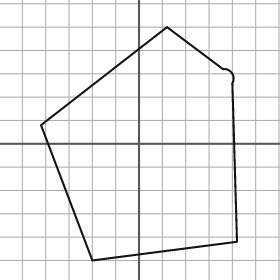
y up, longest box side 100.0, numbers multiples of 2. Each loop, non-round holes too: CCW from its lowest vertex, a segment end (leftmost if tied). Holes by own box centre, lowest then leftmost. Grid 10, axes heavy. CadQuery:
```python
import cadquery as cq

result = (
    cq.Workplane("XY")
    .moveTo(-20.0, -50.0)
    .lineTo(42.0, -42.0)
    .lineTo(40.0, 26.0)
    .threePointArc((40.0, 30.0), (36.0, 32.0))
    .lineTo(12.0, 50.0)
    .lineTo(-42.0, 8.0)
    .close()
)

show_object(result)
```